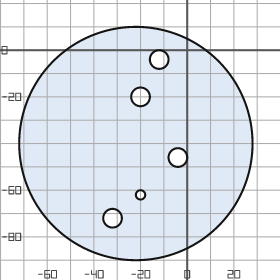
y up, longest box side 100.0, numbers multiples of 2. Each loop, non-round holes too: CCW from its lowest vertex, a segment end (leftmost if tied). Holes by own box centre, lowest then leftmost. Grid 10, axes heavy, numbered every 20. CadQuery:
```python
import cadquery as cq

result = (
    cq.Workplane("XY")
    .moveTo(-22.0, -40.0)
    .circle(50.0)
    .moveTo(-32.0, -72.0)
    .circle(4.0)
    .moveTo(-20.0, -62.0)
    .circle(2.0)
    .moveTo(-4.0, -46.0)
    .circle(4.0)
    .moveTo(-20.0, -20.0)
    .circle(4.0)
    .moveTo(-12.0, -4.0)
    .circle(4.0)
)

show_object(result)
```